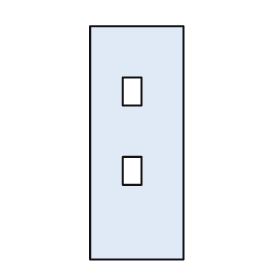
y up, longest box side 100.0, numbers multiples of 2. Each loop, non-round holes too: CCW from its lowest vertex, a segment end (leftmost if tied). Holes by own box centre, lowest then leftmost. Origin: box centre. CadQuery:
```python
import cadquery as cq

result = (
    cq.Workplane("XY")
    .moveTo(-20.0, -50.0)
    .lineTo(20.0, -50.0)
    .lineTo(20.0, 50.0)
    .lineTo(-20.0, 50.0)
    .close()
    .moveTo(-6.0, -18.0)
    .lineTo(2.0, -18.0)
    .lineTo(2.0, -6.0)
    .lineTo(-6.0, -6.0)
    .close()
    .moveTo(-6.0, 16.0)
    .lineTo(2.0, 16.0)
    .lineTo(2.0, 28.0)
    .lineTo(-6.0, 28.0)
    .close()
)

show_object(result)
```